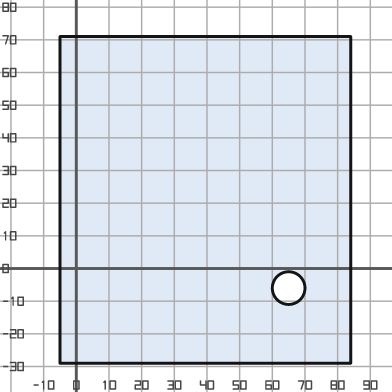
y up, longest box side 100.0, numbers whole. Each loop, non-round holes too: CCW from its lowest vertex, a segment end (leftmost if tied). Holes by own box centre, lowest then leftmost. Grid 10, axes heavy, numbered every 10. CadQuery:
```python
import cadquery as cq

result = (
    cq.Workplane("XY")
    .moveTo(-5.0, -29.0)
    .lineTo(84.0, -29.0)
    .lineTo(84.0, 71.0)
    .lineTo(-5.0, 71.0)
    .close()
    .moveTo(65.0, -6.0)
    .circle(5.0)
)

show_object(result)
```